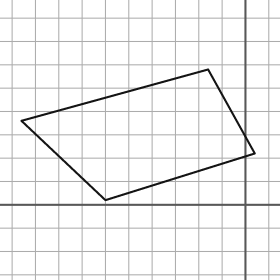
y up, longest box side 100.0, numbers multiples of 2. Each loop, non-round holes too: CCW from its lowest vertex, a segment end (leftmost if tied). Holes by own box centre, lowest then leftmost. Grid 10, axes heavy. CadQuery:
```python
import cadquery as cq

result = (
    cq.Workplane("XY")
    .moveTo(-60.0, 2.0)
    .lineTo(4.0, 22.0)
    .lineTo(-16.0, 58.0)
    .lineTo(-96.0, 36.0)
    .close()
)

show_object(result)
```